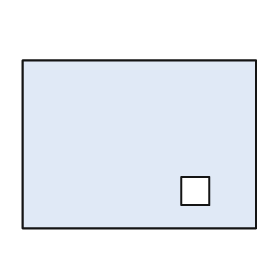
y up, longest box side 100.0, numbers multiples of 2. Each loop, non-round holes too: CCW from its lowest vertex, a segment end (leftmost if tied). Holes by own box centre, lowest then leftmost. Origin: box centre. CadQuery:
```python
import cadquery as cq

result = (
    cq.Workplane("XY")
    .moveTo(-50.0, -36.0)
    .lineTo(50.0, -36.0)
    .lineTo(50.0, 36.0)
    .lineTo(-50.0, 36.0)
    .close()
    .moveTo(18.0, -26.0)
    .lineTo(30.0, -26.0)
    .lineTo(30.0, -14.0)
    .lineTo(18.0, -14.0)
    .close()
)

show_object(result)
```